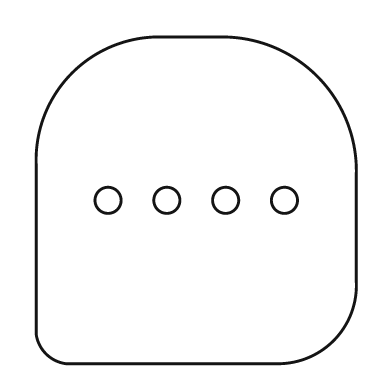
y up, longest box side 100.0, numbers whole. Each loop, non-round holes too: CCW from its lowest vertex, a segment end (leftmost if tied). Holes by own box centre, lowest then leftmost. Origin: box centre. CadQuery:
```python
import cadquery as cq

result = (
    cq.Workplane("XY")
    .moveTo(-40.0, -50.0)
    .lineTo(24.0, -50.0)
    .threePointArc((42.0, -43.0), (49.0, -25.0))
    .lineTo(49.0, 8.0)
    .threePointArc((37.0, 38.0), (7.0, 50.0))
    .lineTo(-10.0, 50.0)
    .threePointArc((-38.0, 39.0), (-49.0, 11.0))
    .lineTo(-49.0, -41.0)
    .threePointArc((-46.0, -47.0), (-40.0, -50.0))
    .close()
    .moveTo(-27.0, 0.0)
    .circle(4.0)
    .moveTo(-9.0, 0.0)
    .circle(4.0)
    .moveTo(9.0, 0.0)
    .circle(4.0)
    .moveTo(27.0, 0.0)
    .circle(4.0)
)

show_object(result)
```